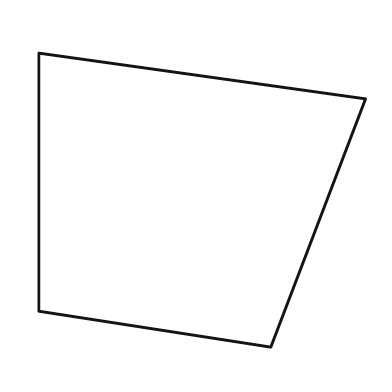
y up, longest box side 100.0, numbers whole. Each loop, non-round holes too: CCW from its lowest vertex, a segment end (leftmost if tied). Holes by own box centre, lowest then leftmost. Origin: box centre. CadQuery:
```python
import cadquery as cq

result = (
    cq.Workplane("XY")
    .moveTo(21.0, -45.0)
    .lineTo(50.0, 31.0)
    .lineTo(-50.0, 45.0)
    .lineTo(-50.0, -34.0)
    .close()
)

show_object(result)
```